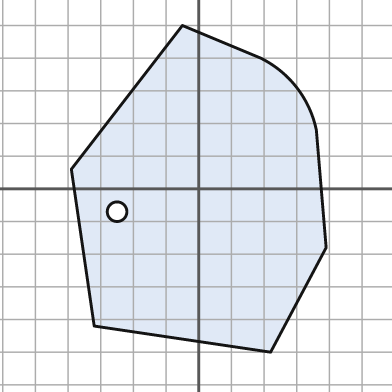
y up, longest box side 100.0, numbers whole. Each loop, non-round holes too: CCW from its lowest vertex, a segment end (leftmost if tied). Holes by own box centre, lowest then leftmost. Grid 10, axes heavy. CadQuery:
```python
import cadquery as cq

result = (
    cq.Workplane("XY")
    .moveTo(22.0, -50.0)
    .lineTo(39.0, -18.0)
    .lineTo(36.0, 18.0)
    .threePointArc((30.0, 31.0), (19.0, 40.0))
    .lineTo(-5.0, 50.0)
    .lineTo(-39.0, 6.0)
    .lineTo(-32.0, -42.0)
    .close()
    .moveTo(-25.0, -7.0)
    .circle(3.0)
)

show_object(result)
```